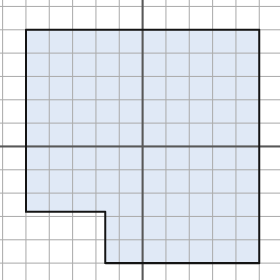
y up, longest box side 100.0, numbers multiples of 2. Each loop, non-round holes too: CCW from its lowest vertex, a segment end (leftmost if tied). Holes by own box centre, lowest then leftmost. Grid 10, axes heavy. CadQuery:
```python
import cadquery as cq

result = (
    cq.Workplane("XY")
    .moveTo(-16.0, -50.0)
    .lineTo(50.0, -50.0)
    .lineTo(50.0, 50.0)
    .lineTo(-50.0, 50.0)
    .lineTo(-50.0, -28.0)
    .lineTo(-16.0, -28.0)
    .close()
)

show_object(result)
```